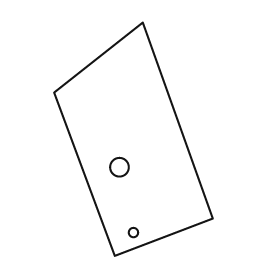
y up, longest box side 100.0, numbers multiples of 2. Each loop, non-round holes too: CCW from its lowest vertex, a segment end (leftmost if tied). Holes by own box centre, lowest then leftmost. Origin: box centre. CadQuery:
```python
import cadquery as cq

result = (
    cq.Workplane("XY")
    .moveTo(-8.0, -50.0)
    .lineTo(34.0, -34.0)
    .lineTo(4.0, 50.0)
    .lineTo(-34.0, 20.0)
    .close()
    .moveTo(0.0, -40.0)
    .circle(2.0)
    .moveTo(-6.0, -12.0)
    .circle(4.0)
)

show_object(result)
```